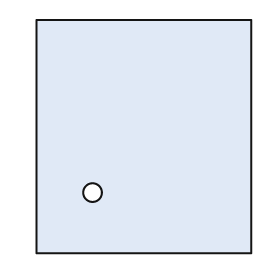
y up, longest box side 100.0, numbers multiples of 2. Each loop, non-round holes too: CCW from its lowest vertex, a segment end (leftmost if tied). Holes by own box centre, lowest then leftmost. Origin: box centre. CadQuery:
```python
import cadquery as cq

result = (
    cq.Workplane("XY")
    .moveTo(-46.0, -50.0)
    .lineTo(46.0, -50.0)
    .lineTo(46.0, 50.0)
    .lineTo(-46.0, 50.0)
    .close()
    .moveTo(-22.0, -24.0)
    .circle(4.0)
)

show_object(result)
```